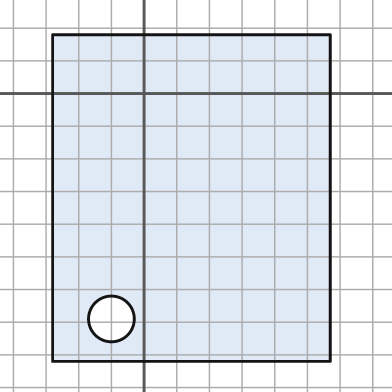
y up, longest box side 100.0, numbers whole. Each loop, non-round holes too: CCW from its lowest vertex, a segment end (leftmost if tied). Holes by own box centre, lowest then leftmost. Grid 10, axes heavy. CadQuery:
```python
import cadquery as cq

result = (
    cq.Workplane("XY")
    .moveTo(-28.0, -82.0)
    .lineTo(57.0, -82.0)
    .lineTo(57.0, 18.0)
    .lineTo(-28.0, 18.0)
    .close()
    .moveTo(-10.0, -69.0)
    .circle(7.0)
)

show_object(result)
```